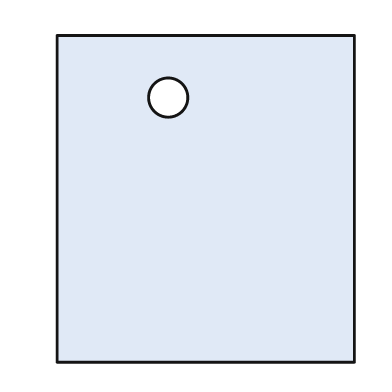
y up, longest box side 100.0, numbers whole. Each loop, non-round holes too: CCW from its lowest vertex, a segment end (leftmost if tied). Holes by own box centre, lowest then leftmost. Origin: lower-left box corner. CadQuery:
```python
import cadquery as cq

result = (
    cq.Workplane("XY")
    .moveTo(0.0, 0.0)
    .lineTo(91.0, 0.0)
    .lineTo(91.0, 100.0)
    .lineTo(0.0, 100.0)
    .close()
    .moveTo(34.0, 81.0)
    .circle(6.0)
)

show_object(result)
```